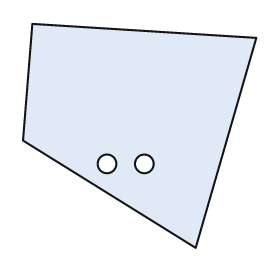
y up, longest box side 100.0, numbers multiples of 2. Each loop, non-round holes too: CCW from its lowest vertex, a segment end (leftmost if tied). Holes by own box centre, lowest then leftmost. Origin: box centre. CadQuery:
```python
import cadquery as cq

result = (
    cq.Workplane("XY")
    .moveTo(24.0, -48.0)
    .lineTo(50.0, 42.0)
    .lineTo(-46.0, 48.0)
    .lineTo(-50.0, -2.0)
    .close()
    .moveTo(-14.0, -12.0)
    .circle(4.0)
    .moveTo(2.0, -12.0)
    .circle(4.0)
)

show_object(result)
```